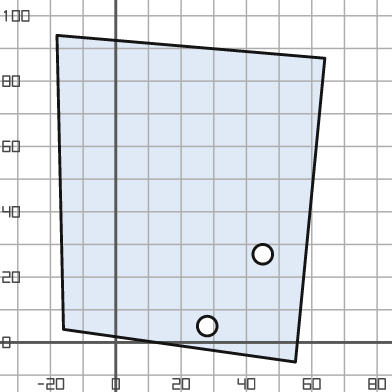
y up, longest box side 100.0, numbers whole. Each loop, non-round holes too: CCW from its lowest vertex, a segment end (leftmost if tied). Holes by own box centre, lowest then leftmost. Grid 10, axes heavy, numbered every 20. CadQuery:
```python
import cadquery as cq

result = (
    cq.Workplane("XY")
    .moveTo(55.0, -6.0)
    .lineTo(64.0, 87.0)
    .lineTo(-18.0, 94.0)
    .lineTo(-16.0, 4.0)
    .close()
    .moveTo(28.0, 5.0)
    .circle(3.0)
    .moveTo(45.0, 27.0)
    .circle(3.0)
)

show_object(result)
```